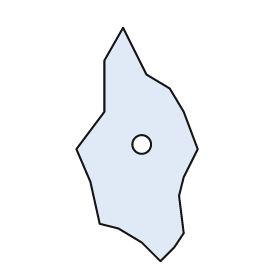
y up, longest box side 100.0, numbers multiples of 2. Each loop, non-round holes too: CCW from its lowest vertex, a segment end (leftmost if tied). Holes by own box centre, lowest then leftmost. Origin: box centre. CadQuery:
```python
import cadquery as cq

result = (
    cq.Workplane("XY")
    .moveTo(10.0, -50.0)
    .lineTo(16.0, -44.0)
    .lineTo(20.0, -38.0)
    .lineTo(18.0, -22.0)
    .lineTo(20.0, -14.0)
    .lineTo(26.0, -2.0)
    .lineTo(20.0, 14.0)
    .lineTo(14.0, 24.0)
    .lineTo(4.0, 30.0)
    .lineTo(-6.0, 50.0)
    .lineTo(-14.0, 36.0)
    .lineTo(-14.0, 14.0)
    .lineTo(-26.0, -2.0)
    .lineTo(-20.0, -16.0)
    .lineTo(-16.0, -34.0)
    .lineTo(-8.0, -36.0)
    .lineTo(2.0, -42.0)
    .close()
    .moveTo(2.0, 0.0)
    .circle(4.0)
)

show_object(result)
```